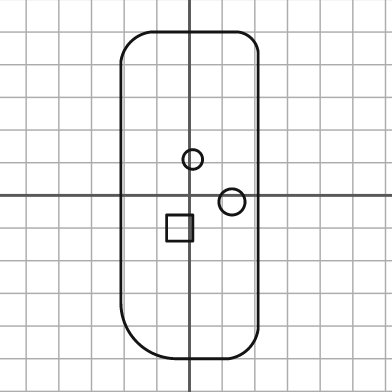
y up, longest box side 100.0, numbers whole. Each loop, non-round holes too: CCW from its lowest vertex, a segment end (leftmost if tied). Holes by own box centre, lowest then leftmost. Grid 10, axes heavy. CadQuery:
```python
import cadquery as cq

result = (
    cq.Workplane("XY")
    .moveTo(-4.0, -50.0)
    .lineTo(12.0, -50.0)
    .threePointArc((18.0, -47.0), (21.0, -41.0))
    .lineTo(21.0, 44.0)
    .threePointArc((19.0, 48.0), (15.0, 50.0))
    .lineTo(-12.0, 50.0)
    .threePointArc((-18.0, 47.0), (-21.0, 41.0))
    .lineTo(-21.0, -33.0)
    .threePointArc((-16.0, -45.0), (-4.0, -50.0))
    .close()
    .moveTo(-7.0, -14.0)
    .lineTo(1.0, -14.0)
    .lineTo(1.0, -6.0)
    .lineTo(-7.0, -6.0)
    .close()
    .moveTo(13.0, -2.0)
    .circle(4.0)
    .moveTo(1.0, 11.0)
    .circle(3.0)
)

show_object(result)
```